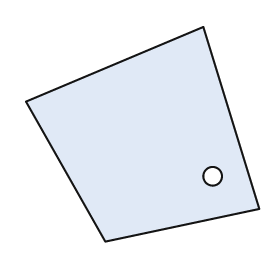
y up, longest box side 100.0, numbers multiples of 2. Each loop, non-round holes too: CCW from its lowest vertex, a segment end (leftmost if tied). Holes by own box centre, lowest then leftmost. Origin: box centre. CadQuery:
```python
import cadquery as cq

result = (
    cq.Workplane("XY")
    .moveTo(-16.0, -46.0)
    .lineTo(50.0, -32.0)
    .lineTo(26.0, 46.0)
    .lineTo(-50.0, 14.0)
    .close()
    .moveTo(30.0, -18.0)
    .circle(4.0)
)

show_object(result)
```